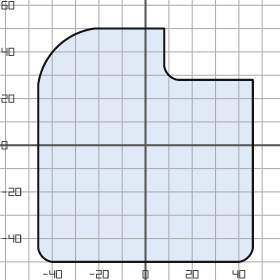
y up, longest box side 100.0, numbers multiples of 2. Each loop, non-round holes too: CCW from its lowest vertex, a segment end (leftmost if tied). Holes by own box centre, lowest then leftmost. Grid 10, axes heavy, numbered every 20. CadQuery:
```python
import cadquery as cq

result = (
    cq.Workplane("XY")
    .moveTo(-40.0, -50.0)
    .lineTo(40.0, -50.0)
    .threePointArc((44.0, -48.0), (46.0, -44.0))
    .lineTo(46.0, 28.0)
    .lineTo(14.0, 28.0)
    .threePointArc((10.0, 30.0), (8.0, 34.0))
    .lineTo(8.0, 50.0)
    .lineTo(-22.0, 50.0)
    .threePointArc((-38.0, 42.0), (-46.0, 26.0))
    .lineTo(-46.0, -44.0)
    .threePointArc((-44.0, -48.0), (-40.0, -50.0))
    .close()
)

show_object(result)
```